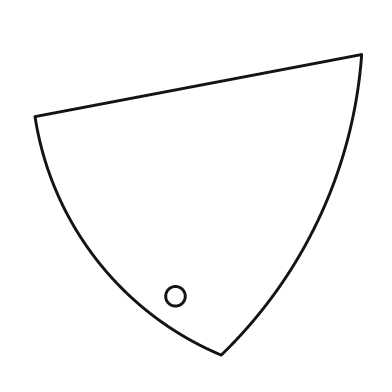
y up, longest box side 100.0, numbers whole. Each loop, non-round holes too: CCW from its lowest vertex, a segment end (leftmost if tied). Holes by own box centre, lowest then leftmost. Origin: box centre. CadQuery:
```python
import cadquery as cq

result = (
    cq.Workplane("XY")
    .moveTo(7.0, -46.0)
    .threePointArc((37.0, -4.0), (50.0, 46.0))
    .lineTo(-50.0, 27.0)
    .threePointArc((-31.0, -17.0), (7.0, -46.0))
    .close()
    .moveTo(-7.0, -28.0)
    .circle(3.0)
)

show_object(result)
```